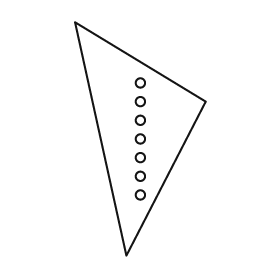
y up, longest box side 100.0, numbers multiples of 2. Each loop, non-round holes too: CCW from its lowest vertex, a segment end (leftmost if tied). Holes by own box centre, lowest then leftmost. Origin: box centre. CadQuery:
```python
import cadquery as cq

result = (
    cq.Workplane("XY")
    .moveTo(-6.0, -50.0)
    .lineTo(28.0, 16.0)
    .lineTo(-28.0, 50.0)
    .close()
    .moveTo(0.0, -24.0)
    .circle(2.0)
    .moveTo(0.0, -16.0)
    .circle(2.0)
    .moveTo(0.0, -8.0)
    .circle(2.0)
    .moveTo(0.0, 0.0)
    .circle(2.0)
    .moveTo(0.0, 8.0)
    .circle(2.0)
    .moveTo(0.0, 16.0)
    .circle(2.0)
    .moveTo(0.0, 24.0)
    .circle(2.0)
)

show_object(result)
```